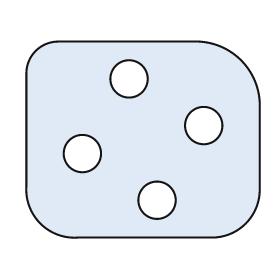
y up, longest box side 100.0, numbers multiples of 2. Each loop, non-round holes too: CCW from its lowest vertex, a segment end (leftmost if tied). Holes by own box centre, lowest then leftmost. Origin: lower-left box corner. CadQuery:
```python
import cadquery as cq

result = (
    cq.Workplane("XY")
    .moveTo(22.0, 0.0)
    .lineTo(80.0, 0.0)
    .threePointArc((94.0, 6.0), (100.0, 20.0))
    .lineTo(100.0, 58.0)
    .threePointArc((92.0, 76.0), (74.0, 84.0))
    .lineTo(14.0, 84.0)
    .threePointArc((4.0, 80.0), (0.0, 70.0))
    .lineTo(0.0, 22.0)
    .threePointArc((6.0, 6.0), (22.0, 0.0))
    .close()
    .moveTo(56.0, 16.0)
    .circle(8.0)
    .moveTo(24.0, 36.0)
    .circle(8.0)
    .moveTo(76.0, 48.0)
    .circle(8.0)
    .moveTo(44.0, 68.0)
    .circle(8.0)
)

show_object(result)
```